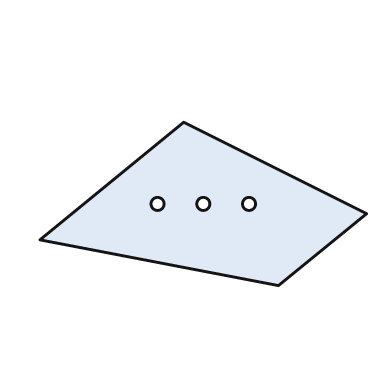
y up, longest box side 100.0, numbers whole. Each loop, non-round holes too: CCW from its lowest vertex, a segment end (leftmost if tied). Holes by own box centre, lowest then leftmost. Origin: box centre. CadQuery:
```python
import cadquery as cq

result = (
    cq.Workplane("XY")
    .moveTo(23.0, -25.0)
    .lineTo(50.0, -3.0)
    .lineTo(-6.0, 25.0)
    .lineTo(-50.0, -11.0)
    .close()
    .moveTo(-14.0, 0.0)
    .circle(2.0)
    .moveTo(0.0, 0.0)
    .circle(2.0)
    .moveTo(14.0, 0.0)
    .circle(2.0)
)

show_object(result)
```